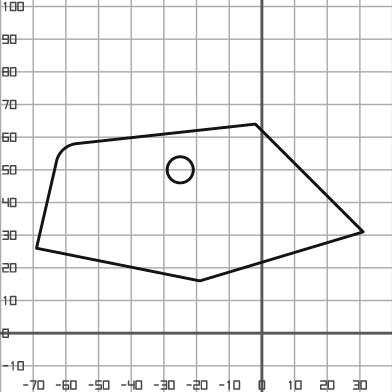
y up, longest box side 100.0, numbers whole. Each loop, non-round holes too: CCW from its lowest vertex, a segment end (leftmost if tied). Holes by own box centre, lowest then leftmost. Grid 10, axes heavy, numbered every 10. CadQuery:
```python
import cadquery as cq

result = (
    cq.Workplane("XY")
    .moveTo(-19.0, 16.0)
    .lineTo(31.0, 31.0)
    .lineTo(-2.0, 64.0)
    .lineTo(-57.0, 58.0)
    .threePointArc((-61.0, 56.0), (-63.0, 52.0))
    .lineTo(-69.0, 26.0)
    .close()
    .moveTo(-25.0, 50.0)
    .circle(4.0)
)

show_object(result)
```